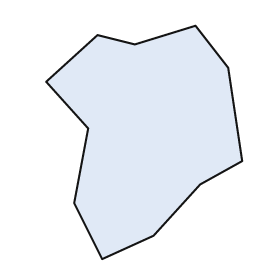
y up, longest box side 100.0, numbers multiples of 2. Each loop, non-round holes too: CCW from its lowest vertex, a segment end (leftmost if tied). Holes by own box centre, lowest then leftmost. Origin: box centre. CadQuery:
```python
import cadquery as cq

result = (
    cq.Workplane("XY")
    .moveTo(-18.0, -50.0)
    .lineTo(4.0, -40.0)
    .lineTo(24.0, -18.0)
    .lineTo(42.0, -8.0)
    .lineTo(36.0, 32.0)
    .lineTo(22.0, 50.0)
    .lineTo(-4.0, 42.0)
    .lineTo(-20.0, 46.0)
    .lineTo(-42.0, 26.0)
    .lineTo(-24.0, 6.0)
    .lineTo(-30.0, -26.0)
    .close()
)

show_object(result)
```